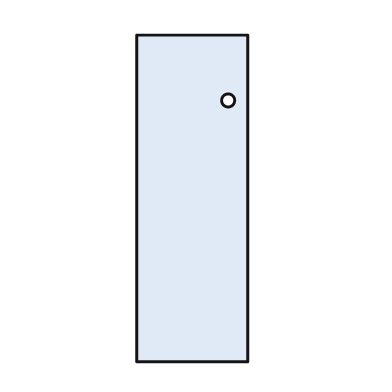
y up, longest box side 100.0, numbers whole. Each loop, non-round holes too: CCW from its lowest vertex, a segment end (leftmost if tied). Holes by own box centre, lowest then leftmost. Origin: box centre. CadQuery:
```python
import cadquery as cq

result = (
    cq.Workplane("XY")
    .moveTo(-17.0, -50.0)
    .lineTo(17.0, -50.0)
    .lineTo(17.0, 50.0)
    .lineTo(-17.0, 50.0)
    .close()
    .moveTo(11.0, 30.0)
    .circle(2.0)
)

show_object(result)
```